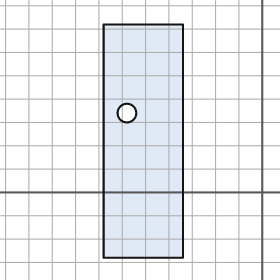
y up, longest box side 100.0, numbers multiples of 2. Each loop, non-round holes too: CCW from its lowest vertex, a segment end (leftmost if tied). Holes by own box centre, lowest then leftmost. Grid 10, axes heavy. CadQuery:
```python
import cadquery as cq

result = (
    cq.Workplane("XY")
    .moveTo(-68.0, -28.0)
    .lineTo(-34.0, -28.0)
    .lineTo(-34.0, 72.0)
    .lineTo(-68.0, 72.0)
    .close()
    .moveTo(-58.0, 34.0)
    .circle(4.0)
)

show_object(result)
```